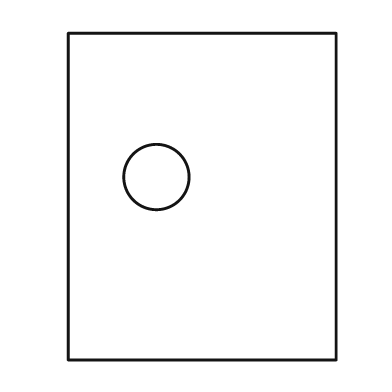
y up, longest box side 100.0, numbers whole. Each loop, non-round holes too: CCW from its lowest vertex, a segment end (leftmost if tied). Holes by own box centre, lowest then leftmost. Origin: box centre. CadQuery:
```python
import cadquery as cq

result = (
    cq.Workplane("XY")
    .moveTo(-41.0, -50.0)
    .lineTo(41.0, -50.0)
    .lineTo(41.0, 50.0)
    .lineTo(-41.0, 50.0)
    .close()
    .moveTo(-14.0, 6.0)
    .circle(10.0)
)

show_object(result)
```